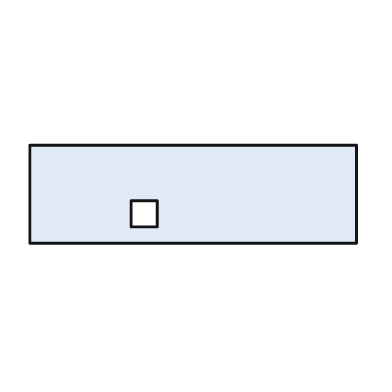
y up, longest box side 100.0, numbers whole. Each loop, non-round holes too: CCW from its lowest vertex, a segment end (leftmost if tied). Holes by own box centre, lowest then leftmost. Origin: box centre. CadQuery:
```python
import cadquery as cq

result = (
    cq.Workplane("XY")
    .moveTo(-50.0, -15.0)
    .lineTo(50.0, -15.0)
    .lineTo(50.0, 15.0)
    .lineTo(-50.0, 15.0)
    .close()
    .moveTo(-19.0, -10.0)
    .lineTo(-11.0, -10.0)
    .lineTo(-11.0, -2.0)
    .lineTo(-19.0, -2.0)
    .close()
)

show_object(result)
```